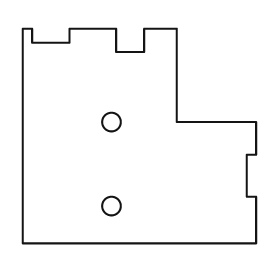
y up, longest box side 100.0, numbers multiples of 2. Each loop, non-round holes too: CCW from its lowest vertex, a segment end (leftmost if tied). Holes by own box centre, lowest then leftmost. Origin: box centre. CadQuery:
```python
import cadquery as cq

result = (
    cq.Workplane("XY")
    .moveTo(-50.0, -46.0)
    .lineTo(50.0, -46.0)
    .lineTo(50.0, -26.0)
    .lineTo(46.0, -26.0)
    .lineTo(46.0, -8.0)
    .lineTo(50.0, -8.0)
    .lineTo(50.0, 6.0)
    .lineTo(16.0, 6.0)
    .lineTo(16.0, 46.0)
    .lineTo(2.0, 46.0)
    .lineTo(2.0, 36.0)
    .lineTo(-10.0, 36.0)
    .lineTo(-10.0, 46.0)
    .lineTo(-30.0, 46.0)
    .lineTo(-30.0, 40.0)
    .lineTo(-46.0, 40.0)
    .lineTo(-46.0, 46.0)
    .lineTo(-50.0, 46.0)
    .close()
    .moveTo(-12.0, -30.0)
    .circle(4.0)
    .moveTo(-12.0, 6.0)
    .circle(4.0)
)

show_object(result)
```